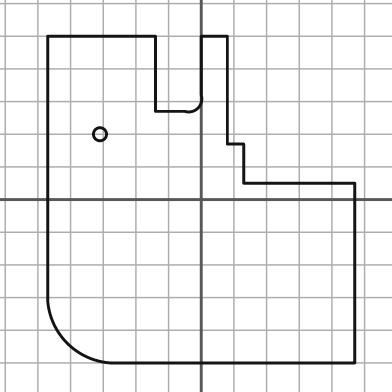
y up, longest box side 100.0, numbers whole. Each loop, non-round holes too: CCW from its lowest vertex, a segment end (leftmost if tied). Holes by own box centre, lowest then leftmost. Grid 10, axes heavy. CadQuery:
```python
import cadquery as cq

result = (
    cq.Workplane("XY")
    .moveTo(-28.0, -50.0)
    .lineTo(47.0, -50.0)
    .lineTo(47.0, 5.0)
    .lineTo(13.0, 5.0)
    .lineTo(13.0, 17.0)
    .lineTo(8.0, 17.0)
    .lineTo(8.0, 50.0)
    .lineTo(0.0, 50.0)
    .lineTo(0.0, 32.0)
    .threePointArc((-1.0, 28.0), (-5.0, 27.0))
    .lineTo(-14.0, 27.0)
    .lineTo(-14.0, 50.0)
    .lineTo(-47.0, 50.0)
    .lineTo(-47.0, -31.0)
    .threePointArc((-41.0, -44.0), (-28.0, -50.0))
    .close()
    .moveTo(-31.0, 20.0)
    .circle(2.0)
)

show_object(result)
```